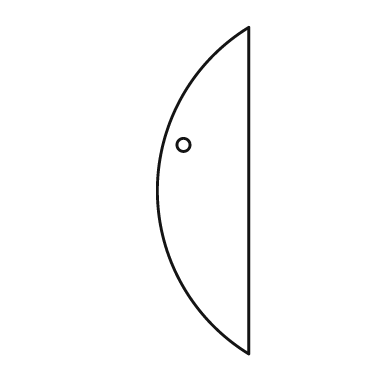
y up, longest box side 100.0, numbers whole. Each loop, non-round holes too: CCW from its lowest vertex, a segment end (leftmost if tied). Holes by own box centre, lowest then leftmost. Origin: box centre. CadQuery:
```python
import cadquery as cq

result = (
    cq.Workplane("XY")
    .moveTo(14.0, -50.0)
    .lineTo(14.0, 50.0)
    .threePointArc((-14.0, 0.0), (14.0, -50.0))
    .close()
    .moveTo(-6.0, 14.0)
    .circle(2.0)
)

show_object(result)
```